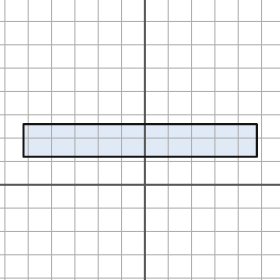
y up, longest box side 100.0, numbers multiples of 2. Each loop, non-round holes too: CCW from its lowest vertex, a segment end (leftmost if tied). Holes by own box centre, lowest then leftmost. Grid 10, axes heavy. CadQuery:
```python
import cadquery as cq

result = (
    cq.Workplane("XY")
    .moveTo(-52.0, 12.0)
    .lineTo(48.0, 12.0)
    .lineTo(48.0, 26.0)
    .lineTo(-52.0, 26.0)
    .close()
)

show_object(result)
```